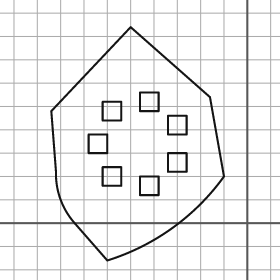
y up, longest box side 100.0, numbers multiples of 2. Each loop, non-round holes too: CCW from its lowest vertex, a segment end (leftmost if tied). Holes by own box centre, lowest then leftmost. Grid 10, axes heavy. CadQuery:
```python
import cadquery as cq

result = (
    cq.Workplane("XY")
    .moveTo(-60.0, -16.0)
    .threePointArc((-32.0, -2.0), (-10.0, 20.0))
    .lineTo(-16.0, 54.0)
    .lineTo(-50.0, 84.0)
    .lineTo(-84.0, 48.0)
    .lineTo(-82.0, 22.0)
    .threePointArc((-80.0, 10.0), (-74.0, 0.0))
    .close()
    .moveTo(-46.0, 12.0)
    .lineTo(-38.0, 12.0)
    .lineTo(-38.0, 20.0)
    .lineTo(-46.0, 20.0)
    .close()
    .moveTo(-62.0, 16.0)
    .lineTo(-54.0, 16.0)
    .lineTo(-54.0, 24.0)
    .lineTo(-62.0, 24.0)
    .close()
    .moveTo(-34.0, 22.0)
    .lineTo(-26.0, 22.0)
    .lineTo(-26.0, 30.0)
    .lineTo(-34.0, 30.0)
    .close()
    .moveTo(-68.0, 30.0)
    .lineTo(-60.0, 30.0)
    .lineTo(-60.0, 38.0)
    .lineTo(-68.0, 38.0)
    .close()
    .moveTo(-34.0, 38.0)
    .lineTo(-26.0, 38.0)
    .lineTo(-26.0, 46.0)
    .lineTo(-34.0, 46.0)
    .close()
    .moveTo(-62.0, 44.0)
    .lineTo(-54.0, 44.0)
    .lineTo(-54.0, 52.0)
    .lineTo(-62.0, 52.0)
    .close()
    .moveTo(-46.0, 48.0)
    .lineTo(-38.0, 48.0)
    .lineTo(-38.0, 56.0)
    .lineTo(-46.0, 56.0)
    .close()
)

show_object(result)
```